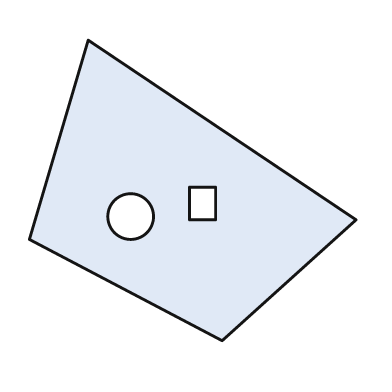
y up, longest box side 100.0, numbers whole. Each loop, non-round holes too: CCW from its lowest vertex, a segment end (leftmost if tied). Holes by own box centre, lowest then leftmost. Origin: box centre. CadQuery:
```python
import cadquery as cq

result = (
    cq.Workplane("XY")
    .moveTo(9.0, -46.0)
    .lineTo(50.0, -9.0)
    .lineTo(-32.0, 46.0)
    .lineTo(-50.0, -15.0)
    .close()
    .moveTo(-19.0, -8.0)
    .circle(7.0)
    .moveTo(-1.0, -9.0)
    .lineTo(7.0, -9.0)
    .lineTo(7.0, 1.0)
    .lineTo(-1.0, 1.0)
    .close()
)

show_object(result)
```